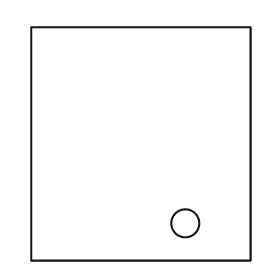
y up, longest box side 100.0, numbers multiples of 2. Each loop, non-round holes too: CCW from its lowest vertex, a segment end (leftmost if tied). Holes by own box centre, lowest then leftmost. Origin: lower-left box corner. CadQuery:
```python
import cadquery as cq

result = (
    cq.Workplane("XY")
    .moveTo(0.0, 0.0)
    .lineTo(94.0, 0.0)
    .lineTo(94.0, 100.0)
    .lineTo(0.0, 100.0)
    .close()
    .moveTo(66.0, 16.0)
    .circle(6.0)
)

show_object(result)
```